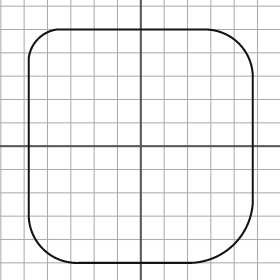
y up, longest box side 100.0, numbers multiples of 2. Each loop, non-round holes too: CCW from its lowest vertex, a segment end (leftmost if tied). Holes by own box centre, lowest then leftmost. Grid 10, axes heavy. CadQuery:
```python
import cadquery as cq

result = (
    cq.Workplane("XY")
    .moveTo(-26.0, -50.0)
    .lineTo(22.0, -50.0)
    .threePointArc((40.0, -42.0), (48.0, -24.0))
    .lineTo(48.0, 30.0)
    .threePointArc((42.0, 44.0), (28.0, 50.0))
    .lineTo(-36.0, 50.0)
    .threePointArc((-44.0, 46.0), (-48.0, 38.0))
    .lineTo(-48.0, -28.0)
    .threePointArc((-42.0, -44.0), (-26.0, -50.0))
    .close()
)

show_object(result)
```